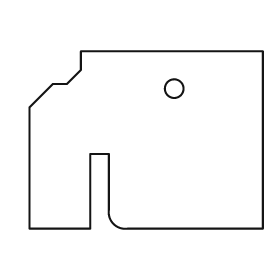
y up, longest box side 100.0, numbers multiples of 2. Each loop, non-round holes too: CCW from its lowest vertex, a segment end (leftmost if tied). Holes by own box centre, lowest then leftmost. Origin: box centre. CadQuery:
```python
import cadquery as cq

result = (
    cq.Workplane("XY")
    .moveTo(-50.0, -38.0)
    .lineTo(-24.0, -38.0)
    .lineTo(-24.0, -6.0)
    .lineTo(-16.0, -6.0)
    .lineTo(-16.0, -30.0)
    .threePointArc((-14.0, -36.0), (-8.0, -38.0))
    .lineTo(50.0, -38.0)
    .lineTo(50.0, 38.0)
    .lineTo(-28.0, 38.0)
    .lineTo(-28.0, 30.0)
    .lineTo(-34.0, 24.0)
    .lineTo(-40.0, 24.0)
    .lineTo(-50.0, 14.0)
    .close()
    .moveTo(12.0, 22.0)
    .circle(4.0)
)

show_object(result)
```